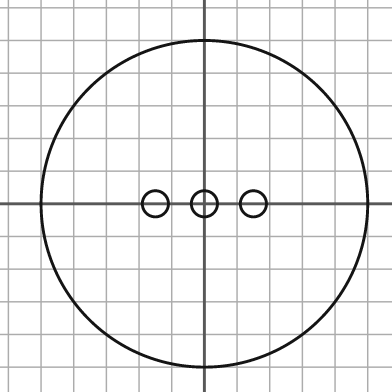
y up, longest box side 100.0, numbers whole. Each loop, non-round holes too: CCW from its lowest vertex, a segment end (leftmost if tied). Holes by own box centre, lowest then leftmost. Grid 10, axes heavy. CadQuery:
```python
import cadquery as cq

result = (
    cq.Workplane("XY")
    .moveTo(0.0, 0.0)
    .circle(50.0)
    .moveTo(-15.0, 0.0)
    .circle(4.0)
    .moveTo(0.0, 0.0)
    .circle(4.0)
    .moveTo(15.0, 0.0)
    .circle(4.0)
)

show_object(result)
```